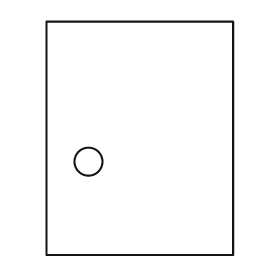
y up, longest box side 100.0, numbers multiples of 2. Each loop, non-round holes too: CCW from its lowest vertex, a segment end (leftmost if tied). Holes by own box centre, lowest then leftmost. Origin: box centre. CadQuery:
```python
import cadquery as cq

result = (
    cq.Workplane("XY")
    .moveTo(-40.0, -50.0)
    .lineTo(40.0, -50.0)
    .lineTo(40.0, 50.0)
    .lineTo(-40.0, 50.0)
    .close()
    .moveTo(-22.0, -10.0)
    .circle(6.0)
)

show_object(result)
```